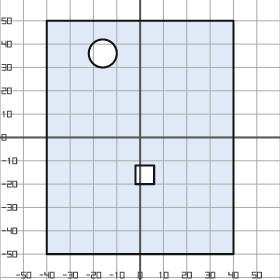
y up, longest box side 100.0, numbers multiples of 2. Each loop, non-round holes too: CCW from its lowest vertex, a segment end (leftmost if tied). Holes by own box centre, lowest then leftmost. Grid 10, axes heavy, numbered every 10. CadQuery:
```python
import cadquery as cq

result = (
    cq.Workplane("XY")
    .moveTo(-40.0, -50.0)
    .lineTo(40.0, -50.0)
    .lineTo(40.0, 50.0)
    .lineTo(-40.0, 50.0)
    .close()
    .moveTo(-2.0, -20.0)
    .lineTo(6.0, -20.0)
    .lineTo(6.0, -12.0)
    .lineTo(-2.0, -12.0)
    .close()
    .moveTo(-16.0, 36.0)
    .circle(6.0)
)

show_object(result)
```